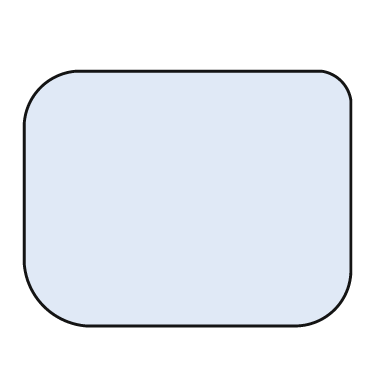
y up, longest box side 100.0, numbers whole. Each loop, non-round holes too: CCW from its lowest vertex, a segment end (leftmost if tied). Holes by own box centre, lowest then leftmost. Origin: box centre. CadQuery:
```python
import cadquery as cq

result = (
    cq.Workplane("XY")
    .moveTo(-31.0, -39.0)
    .lineTo(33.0, -39.0)
    .threePointArc((45.0, -34.0), (50.0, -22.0))
    .lineTo(50.0, 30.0)
    .threePointArc((47.0, 36.0), (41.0, 39.0))
    .lineTo(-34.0, 39.0)
    .threePointArc((-45.0, 34.0), (-50.0, 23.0))
    .lineTo(-50.0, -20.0)
    .threePointArc((-44.0, -33.0), (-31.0, -39.0))
    .close()
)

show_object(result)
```